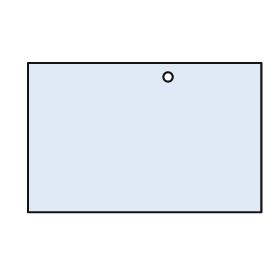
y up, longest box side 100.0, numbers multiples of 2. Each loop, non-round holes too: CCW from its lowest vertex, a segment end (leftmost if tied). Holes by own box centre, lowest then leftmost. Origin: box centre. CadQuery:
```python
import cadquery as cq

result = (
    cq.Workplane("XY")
    .moveTo(-50.0, -32.0)
    .lineTo(50.0, -32.0)
    .lineTo(50.0, 32.0)
    .lineTo(-50.0, 32.0)
    .close()
    .moveTo(10.0, 26.0)
    .circle(2.0)
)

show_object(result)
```